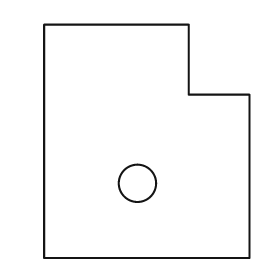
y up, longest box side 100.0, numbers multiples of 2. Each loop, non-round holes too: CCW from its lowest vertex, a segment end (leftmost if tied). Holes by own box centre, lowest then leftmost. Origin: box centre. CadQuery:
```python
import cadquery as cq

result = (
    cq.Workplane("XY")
    .moveTo(-44.0, -50.0)
    .lineTo(44.0, -50.0)
    .lineTo(44.0, 20.0)
    .lineTo(18.0, 20.0)
    .lineTo(18.0, 50.0)
    .lineTo(-44.0, 50.0)
    .close()
    .moveTo(-4.0, -18.0)
    .circle(8.0)
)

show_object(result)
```